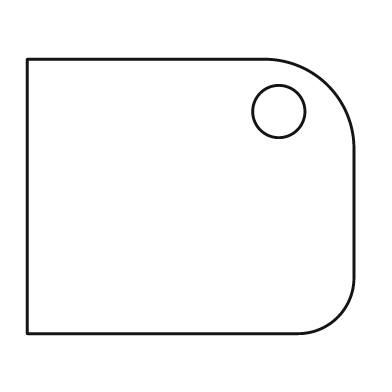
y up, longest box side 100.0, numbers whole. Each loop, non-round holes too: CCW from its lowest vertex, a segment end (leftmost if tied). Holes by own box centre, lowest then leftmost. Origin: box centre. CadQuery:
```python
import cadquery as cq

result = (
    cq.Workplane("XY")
    .moveTo(-50.0, -42.0)
    .lineTo(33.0, -42.0)
    .threePointArc((45.0, -37.0), (50.0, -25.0))
    .lineTo(50.0, 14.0)
    .threePointArc((42.0, 34.0), (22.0, 42.0))
    .lineTo(-50.0, 42.0)
    .close()
    .moveTo(27.0, 26.0)
    .circle(8.0)
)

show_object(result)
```